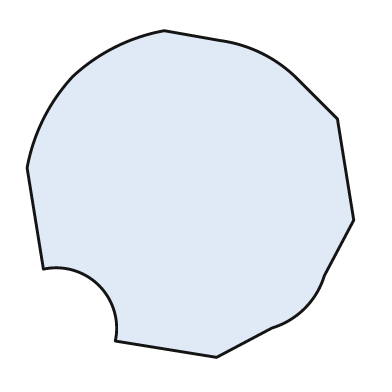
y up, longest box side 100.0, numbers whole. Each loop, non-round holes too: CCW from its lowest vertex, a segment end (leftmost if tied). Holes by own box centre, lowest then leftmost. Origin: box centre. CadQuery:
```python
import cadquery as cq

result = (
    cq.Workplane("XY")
    .moveTo(8.0, -50.0)
    .lineTo(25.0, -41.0)
    .threePointArc((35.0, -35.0), (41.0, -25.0))
    .lineTo(50.0, -8.0)
    .lineTo(45.0, 23.0)
    .lineTo(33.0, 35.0)
    .threePointArc((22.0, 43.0), (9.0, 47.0))
    .lineTo(-8.0, 50.0)
    .threePointArc((-23.0, 45.0), (-36.0, 36.0))
    .threePointArc((-45.0, 23.0), (-50.0, 8.0))
    .lineTo(-45.0, -23.0)
    .threePointArc((-28.0, -28.0), (-23.0, -45.0))
    .close()
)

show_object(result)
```